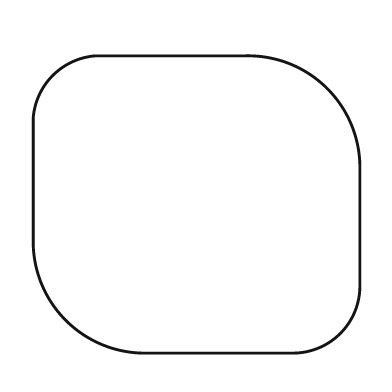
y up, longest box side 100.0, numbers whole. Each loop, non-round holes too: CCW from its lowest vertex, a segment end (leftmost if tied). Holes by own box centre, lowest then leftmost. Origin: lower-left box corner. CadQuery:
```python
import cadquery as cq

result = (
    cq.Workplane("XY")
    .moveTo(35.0, 0.0)
    .lineTo(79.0, 0.0)
    .threePointArc((94.0, 6.0), (100.0, 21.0))
    .lineTo(100.0, 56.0)
    .threePointArc((90.0, 81.0), (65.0, 91.0))
    .lineTo(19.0, 91.0)
    .threePointArc((6.0, 85.0), (0.0, 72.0))
    .lineTo(0.0, 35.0)
    .threePointArc((10.0, 10.0), (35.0, 0.0))
    .close()
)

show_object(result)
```